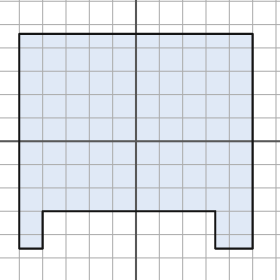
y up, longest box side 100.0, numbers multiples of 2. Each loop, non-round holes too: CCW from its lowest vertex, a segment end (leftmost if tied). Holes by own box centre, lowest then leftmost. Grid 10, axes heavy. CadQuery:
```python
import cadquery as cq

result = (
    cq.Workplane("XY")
    .moveTo(-50.0, -46.0)
    .lineTo(-40.0, -46.0)
    .lineTo(-40.0, -30.0)
    .lineTo(34.0, -30.0)
    .lineTo(34.0, -46.0)
    .lineTo(50.0, -46.0)
    .lineTo(50.0, 46.0)
    .lineTo(-50.0, 46.0)
    .close()
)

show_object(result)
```